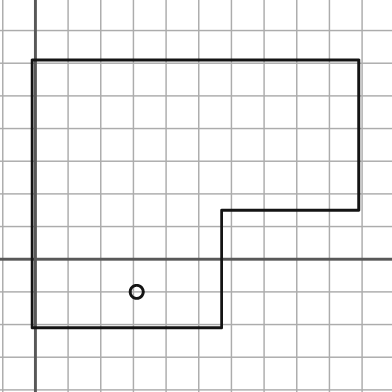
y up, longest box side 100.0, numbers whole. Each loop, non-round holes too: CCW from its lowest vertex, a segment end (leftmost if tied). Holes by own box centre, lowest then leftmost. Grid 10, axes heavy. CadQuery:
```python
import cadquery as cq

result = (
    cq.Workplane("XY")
    .moveTo(-1.0, -21.0)
    .lineTo(57.0, -21.0)
    .lineTo(57.0, 15.0)
    .lineTo(99.0, 15.0)
    .lineTo(99.0, 61.0)
    .lineTo(-1.0, 61.0)
    .close()
    .moveTo(31.0, -10.0)
    .circle(2.0)
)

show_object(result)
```